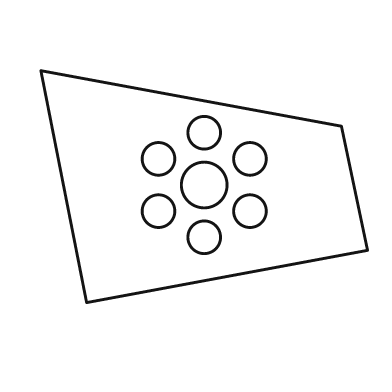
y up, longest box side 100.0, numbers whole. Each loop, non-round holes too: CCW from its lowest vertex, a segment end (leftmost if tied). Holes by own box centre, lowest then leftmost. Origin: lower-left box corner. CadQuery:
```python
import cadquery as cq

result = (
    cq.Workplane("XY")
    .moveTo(14.0, 0.0)
    .lineTo(100.0, 16.0)
    .lineTo(92.0, 54.0)
    .lineTo(0.0, 71.0)
    .close()
    .moveTo(50.0, 20.0)
    .circle(5.0)
    .moveTo(36.0, 28.0)
    .circle(5.0)
    .moveTo(64.0, 28.0)
    .circle(5.0)
    .moveTo(50.0, 36.0)
    .circle(7.0)
    .moveTo(36.0, 44.0)
    .circle(5.0)
    .moveTo(64.0, 44.0)
    .circle(5.0)
    .moveTo(50.0, 52.0)
    .circle(5.0)
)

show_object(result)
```